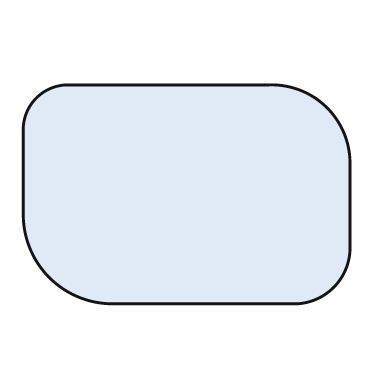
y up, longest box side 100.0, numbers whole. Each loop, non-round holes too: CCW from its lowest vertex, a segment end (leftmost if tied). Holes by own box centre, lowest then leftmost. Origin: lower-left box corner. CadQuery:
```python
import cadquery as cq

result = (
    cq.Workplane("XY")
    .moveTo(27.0, 0.0)
    .lineTo(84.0, 0.0)
    .threePointArc((95.0, 5.0), (100.0, 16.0))
    .lineTo(100.0, 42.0)
    .threePointArc((93.0, 60.0), (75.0, 67.0))
    .lineTo(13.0, 67.0)
    .threePointArc((4.0, 63.0), (0.0, 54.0))
    .lineTo(0.0, 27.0)
    .threePointArc((8.0, 8.0), (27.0, 0.0))
    .close()
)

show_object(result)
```